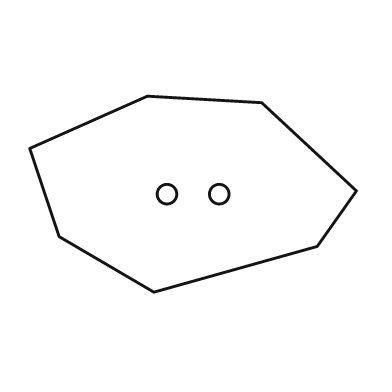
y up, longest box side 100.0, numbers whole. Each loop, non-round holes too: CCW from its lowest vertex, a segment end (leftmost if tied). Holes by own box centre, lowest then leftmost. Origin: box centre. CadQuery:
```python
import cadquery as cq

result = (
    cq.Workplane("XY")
    .moveTo(-12.0, -30.0)
    .lineTo(38.0, -16.0)
    .lineTo(50.0, 1.0)
    .lineTo(21.0, 28.0)
    .lineTo(-14.0, 30.0)
    .lineTo(-50.0, 14.0)
    .lineTo(-41.0, -13.0)
    .close()
    .moveTo(-8.0, 0.0)
    .circle(3.0)
    .moveTo(8.0, 0.0)
    .circle(3.0)
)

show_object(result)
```